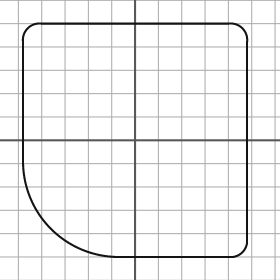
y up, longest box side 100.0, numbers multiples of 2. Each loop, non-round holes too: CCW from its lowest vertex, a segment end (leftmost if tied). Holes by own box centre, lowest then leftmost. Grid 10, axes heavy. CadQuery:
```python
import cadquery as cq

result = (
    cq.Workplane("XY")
    .moveTo(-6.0, -50.0)
    .lineTo(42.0, -50.0)
    .threePointArc((46.0, -48.0), (48.0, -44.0))
    .lineTo(48.0, 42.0)
    .threePointArc((46.0, 48.0), (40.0, 50.0))
    .lineTo(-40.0, 50.0)
    .threePointArc((-46.0, 48.0), (-48.0, 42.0))
    .lineTo(-48.0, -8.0)
    .threePointArc((-36.0, -38.0), (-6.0, -50.0))
    .close()
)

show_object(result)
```